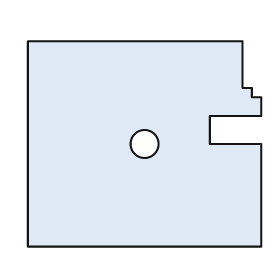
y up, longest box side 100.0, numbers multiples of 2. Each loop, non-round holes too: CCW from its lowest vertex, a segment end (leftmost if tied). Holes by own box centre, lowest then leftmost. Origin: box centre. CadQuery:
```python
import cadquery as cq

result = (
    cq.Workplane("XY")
    .moveTo(-50.0, -44.0)
    .lineTo(50.0, -44.0)
    .lineTo(50.0, 0.0)
    .lineTo(28.0, 0.0)
    .lineTo(28.0, 12.0)
    .lineTo(50.0, 12.0)
    .lineTo(50.0, 20.0)
    .lineTo(46.0, 20.0)
    .lineTo(46.0, 24.0)
    .lineTo(42.0, 24.0)
    .lineTo(42.0, 44.0)
    .lineTo(-50.0, 44.0)
    .close()
    .moveTo(0.0, 0.0)
    .circle(6.0)
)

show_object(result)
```